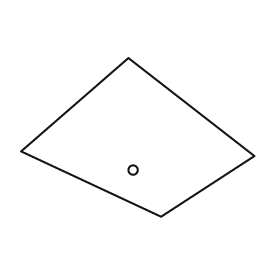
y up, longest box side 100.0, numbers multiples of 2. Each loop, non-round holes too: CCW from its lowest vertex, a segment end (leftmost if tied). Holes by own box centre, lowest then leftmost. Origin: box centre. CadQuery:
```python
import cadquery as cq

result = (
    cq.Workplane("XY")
    .moveTo(10.0, -34.0)
    .lineTo(50.0, -8.0)
    .lineTo(-4.0, 34.0)
    .lineTo(-50.0, -6.0)
    .close()
    .moveTo(-2.0, -14.0)
    .circle(2.0)
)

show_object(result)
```